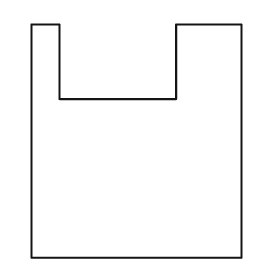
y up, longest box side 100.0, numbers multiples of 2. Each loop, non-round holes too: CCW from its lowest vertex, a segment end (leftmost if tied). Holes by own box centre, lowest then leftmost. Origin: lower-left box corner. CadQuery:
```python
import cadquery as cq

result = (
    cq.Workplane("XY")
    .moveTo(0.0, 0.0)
    .lineTo(90.0, 0.0)
    .lineTo(90.0, 100.0)
    .lineTo(62.0, 100.0)
    .lineTo(62.0, 68.0)
    .lineTo(12.0, 68.0)
    .lineTo(12.0, 100.0)
    .lineTo(0.0, 100.0)
    .close()
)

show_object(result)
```